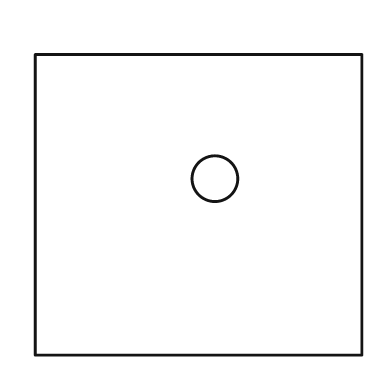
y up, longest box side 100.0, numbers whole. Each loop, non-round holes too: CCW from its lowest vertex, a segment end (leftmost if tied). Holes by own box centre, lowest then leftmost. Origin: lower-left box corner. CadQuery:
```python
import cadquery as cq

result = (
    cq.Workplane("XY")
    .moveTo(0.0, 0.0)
    .lineTo(100.0, 0.0)
    .lineTo(100.0, 92.0)
    .lineTo(0.0, 92.0)
    .close()
    .moveTo(55.0, 54.0)
    .circle(7.0)
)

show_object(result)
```